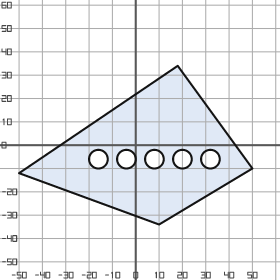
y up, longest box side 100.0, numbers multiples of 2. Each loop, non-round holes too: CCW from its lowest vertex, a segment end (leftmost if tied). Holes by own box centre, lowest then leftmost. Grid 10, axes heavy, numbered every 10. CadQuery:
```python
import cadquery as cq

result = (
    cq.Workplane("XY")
    .moveTo(10.0, -34.0)
    .lineTo(50.0, -10.0)
    .lineTo(18.0, 34.0)
    .lineTo(-50.0, -12.0)
    .close()
    .moveTo(-16.0, -6.0)
    .circle(4.0)
    .moveTo(-4.0, -6.0)
    .circle(4.0)
    .moveTo(8.0, -6.0)
    .circle(4.0)
    .moveTo(20.0, -6.0)
    .circle(4.0)
    .moveTo(32.0, -6.0)
    .circle(4.0)
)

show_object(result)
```